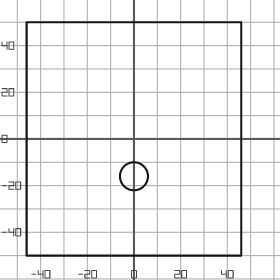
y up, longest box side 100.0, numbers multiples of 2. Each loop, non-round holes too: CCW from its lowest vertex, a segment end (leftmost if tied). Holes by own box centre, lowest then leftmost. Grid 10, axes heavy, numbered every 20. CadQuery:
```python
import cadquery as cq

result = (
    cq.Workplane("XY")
    .moveTo(-46.0, -50.0)
    .lineTo(46.0, -50.0)
    .lineTo(46.0, 50.0)
    .lineTo(-46.0, 50.0)
    .close()
    .moveTo(0.0, -16.0)
    .circle(6.0)
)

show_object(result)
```